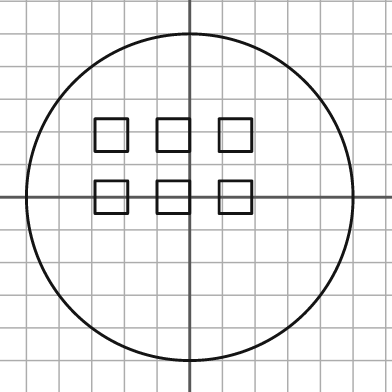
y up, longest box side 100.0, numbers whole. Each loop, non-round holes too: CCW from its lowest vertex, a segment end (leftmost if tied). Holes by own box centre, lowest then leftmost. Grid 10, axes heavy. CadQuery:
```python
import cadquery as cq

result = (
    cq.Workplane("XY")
    .moveTo(0.0, 0.0)
    .circle(50.0)
    .moveTo(-29.0, -5.0)
    .lineTo(-19.0, -5.0)
    .lineTo(-19.0, 5.0)
    .lineTo(-29.0, 5.0)
    .close()
    .moveTo(-10.0, -5.0)
    .lineTo(0.0, -5.0)
    .lineTo(0.0, 5.0)
    .lineTo(-10.0, 5.0)
    .close()
    .moveTo(9.0, -5.0)
    .lineTo(19.0, -5.0)
    .lineTo(19.0, 5.0)
    .lineTo(9.0, 5.0)
    .close()
    .moveTo(-29.0, 14.0)
    .lineTo(-19.0, 14.0)
    .lineTo(-19.0, 24.0)
    .lineTo(-29.0, 24.0)
    .close()
    .moveTo(-10.0, 14.0)
    .lineTo(0.0, 14.0)
    .lineTo(0.0, 24.0)
    .lineTo(-10.0, 24.0)
    .close()
    .moveTo(9.0, 14.0)
    .lineTo(19.0, 14.0)
    .lineTo(19.0, 24.0)
    .lineTo(9.0, 24.0)
    .close()
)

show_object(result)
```